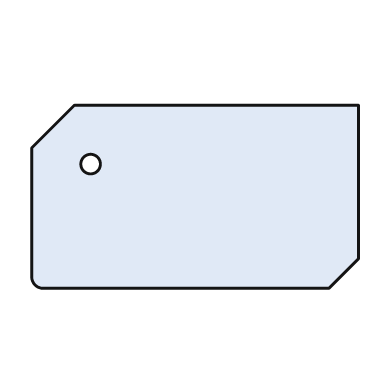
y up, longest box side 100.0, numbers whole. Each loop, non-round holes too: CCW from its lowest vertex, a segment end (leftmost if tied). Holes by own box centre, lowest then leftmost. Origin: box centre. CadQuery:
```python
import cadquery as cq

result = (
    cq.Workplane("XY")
    .moveTo(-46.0, -28.0)
    .lineTo(41.0, -28.0)
    .lineTo(50.0, -19.0)
    .lineTo(50.0, 28.0)
    .lineTo(-37.0, 28.0)
    .lineTo(-50.0, 15.0)
    .lineTo(-50.0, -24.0)
    .threePointArc((-49.0, -27.0), (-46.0, -28.0))
    .close()
    .moveTo(-32.0, 10.0)
    .circle(3.0)
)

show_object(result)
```